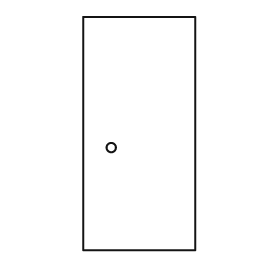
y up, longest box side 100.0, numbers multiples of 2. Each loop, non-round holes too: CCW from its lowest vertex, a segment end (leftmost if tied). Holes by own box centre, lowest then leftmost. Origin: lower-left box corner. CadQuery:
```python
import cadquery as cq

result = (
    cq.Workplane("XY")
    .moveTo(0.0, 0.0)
    .lineTo(48.0, 0.0)
    .lineTo(48.0, 100.0)
    .lineTo(0.0, 100.0)
    .close()
    .moveTo(12.0, 44.0)
    .circle(2.0)
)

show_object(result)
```